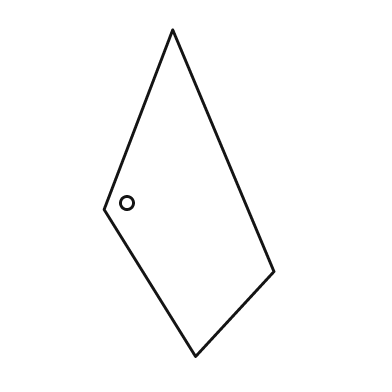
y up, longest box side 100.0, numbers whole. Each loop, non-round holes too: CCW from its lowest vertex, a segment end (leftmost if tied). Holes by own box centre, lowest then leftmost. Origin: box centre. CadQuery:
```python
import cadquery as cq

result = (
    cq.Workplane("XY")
    .moveTo(2.0, -50.0)
    .lineTo(26.0, -24.0)
    .lineTo(-5.0, 50.0)
    .lineTo(-26.0, -5.0)
    .close()
    .moveTo(-19.0, -3.0)
    .circle(2.0)
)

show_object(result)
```